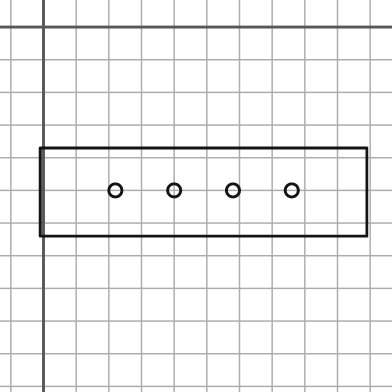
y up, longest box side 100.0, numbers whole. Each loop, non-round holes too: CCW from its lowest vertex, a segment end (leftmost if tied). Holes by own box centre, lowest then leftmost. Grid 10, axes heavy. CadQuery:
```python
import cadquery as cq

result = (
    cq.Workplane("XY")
    .moveTo(-1.0, -64.0)
    .lineTo(99.0, -64.0)
    .lineTo(99.0, -37.0)
    .lineTo(-1.0, -37.0)
    .close()
    .moveTo(22.0, -50.0)
    .circle(2.0)
    .moveTo(40.0, -50.0)
    .circle(2.0)
    .moveTo(58.0, -50.0)
    .circle(2.0)
    .moveTo(76.0, -50.0)
    .circle(2.0)
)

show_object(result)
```